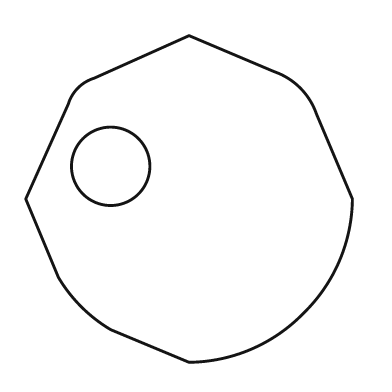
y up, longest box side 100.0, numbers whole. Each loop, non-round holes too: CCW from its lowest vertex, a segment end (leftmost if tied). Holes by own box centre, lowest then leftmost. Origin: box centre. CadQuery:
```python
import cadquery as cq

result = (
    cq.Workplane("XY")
    .moveTo(0.0, -50.0)
    .threePointArc((19.0, -46.0), (35.0, -35.0))
    .threePointArc((46.0, -19.0), (50.0, 0.0))
    .lineTo(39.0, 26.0)
    .threePointArc((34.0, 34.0), (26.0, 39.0))
    .lineTo(0.0, 50.0)
    .lineTo(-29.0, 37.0)
    .threePointArc((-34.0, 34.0), (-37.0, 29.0))
    .lineTo(-50.0, 0.0)
    .lineTo(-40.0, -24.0)
    .threePointArc((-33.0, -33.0), (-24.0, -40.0))
    .close()
    .moveTo(-24.0, 10.0)
    .circle(12.0)
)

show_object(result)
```